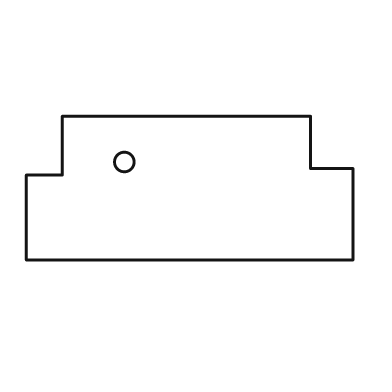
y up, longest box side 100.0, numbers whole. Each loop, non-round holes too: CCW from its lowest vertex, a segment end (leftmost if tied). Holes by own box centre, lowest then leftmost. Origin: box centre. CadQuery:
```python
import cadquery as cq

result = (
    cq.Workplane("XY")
    .moveTo(-50.0, -22.0)
    .lineTo(50.0, -22.0)
    .lineTo(50.0, 6.0)
    .lineTo(37.0, 6.0)
    .lineTo(37.0, 22.0)
    .lineTo(-39.0, 22.0)
    .lineTo(-39.0, 4.0)
    .lineTo(-50.0, 4.0)
    .close()
    .moveTo(-20.0, 8.0)
    .circle(3.0)
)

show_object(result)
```